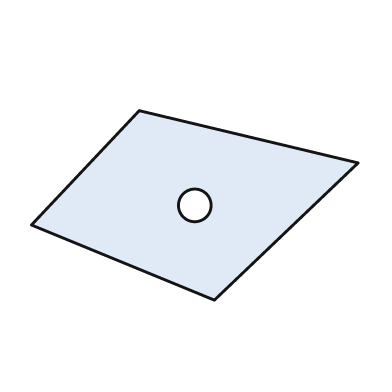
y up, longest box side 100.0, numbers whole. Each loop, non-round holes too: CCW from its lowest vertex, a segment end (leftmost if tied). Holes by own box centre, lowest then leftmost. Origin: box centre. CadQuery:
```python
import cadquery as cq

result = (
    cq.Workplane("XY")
    .moveTo(6.0, -29.0)
    .lineTo(50.0, 13.0)
    .lineTo(-17.0, 29.0)
    .lineTo(-50.0, -6.0)
    .close()
    .moveTo(0.0, 0.0)
    .circle(5.0)
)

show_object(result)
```